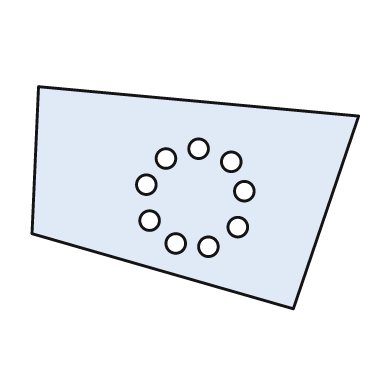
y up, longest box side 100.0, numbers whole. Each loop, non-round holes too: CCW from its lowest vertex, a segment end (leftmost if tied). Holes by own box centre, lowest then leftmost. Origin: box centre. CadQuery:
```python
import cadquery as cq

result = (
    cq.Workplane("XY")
    .moveTo(30.0, -34.0)
    .lineTo(50.0, 25.0)
    .lineTo(-48.0, 34.0)
    .lineTo(-50.0, -11.0)
    .close()
    .moveTo(4.0, -15.0)
    .circle(3.0)
    .moveTo(-6.0, -14.0)
    .circle(3.0)
    .moveTo(13.0, -9.0)
    .circle(3.0)
    .moveTo(-14.0, -7.0)
    .circle(3.0)
    .moveTo(15.0, 2.0)
    .circle(3.0)
    .moveTo(-15.0, 4.0)
    .circle(3.0)
    .moveTo(11.0, 11.0)
    .circle(3.0)
    .moveTo(-9.0, 12.0)
    .circle(3.0)
    .moveTo(1.0, 15.0)
    .circle(3.0)
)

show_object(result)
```